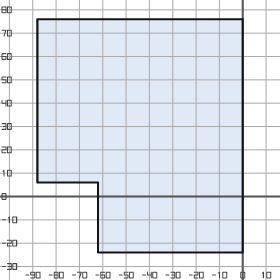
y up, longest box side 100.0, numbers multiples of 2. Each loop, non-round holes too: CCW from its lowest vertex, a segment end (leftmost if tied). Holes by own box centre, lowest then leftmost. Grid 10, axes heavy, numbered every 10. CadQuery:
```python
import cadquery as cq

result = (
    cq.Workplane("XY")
    .moveTo(-62.0, -24.0)
    .lineTo(0.0, -24.0)
    .lineTo(0.0, 76.0)
    .lineTo(-88.0, 76.0)
    .lineTo(-88.0, 6.0)
    .lineTo(-62.0, 6.0)
    .close()
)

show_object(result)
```